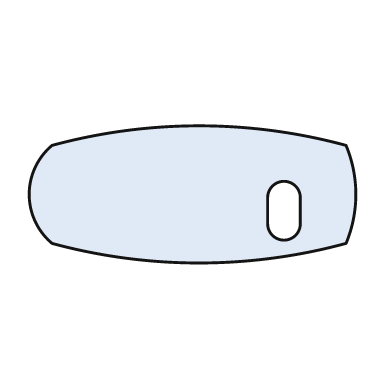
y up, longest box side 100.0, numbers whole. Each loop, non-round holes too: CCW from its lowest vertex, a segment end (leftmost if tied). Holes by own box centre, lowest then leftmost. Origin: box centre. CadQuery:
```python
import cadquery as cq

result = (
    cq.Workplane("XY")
    .moveTo(-43.0, -15.0)
    .threePointArc((2.0, -21.0), (47.0, -15.0))
    .threePointArc((50.0, 0.0), (47.0, 15.0))
    .threePointArc((2.0, 21.0), (-43.0, 15.0))
    .threePointArc((-50.0, 0.0), (-43.0, -15.0))
    .close()
    .moveTo(23.0, -9.0)
    .threePointArc((28.0, -14.0), (33.0, -9.0))
    .lineTo(33.0, -1.0)
    .threePointArc((28.0, 4.0), (23.0, -1.0))
    .close()
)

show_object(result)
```